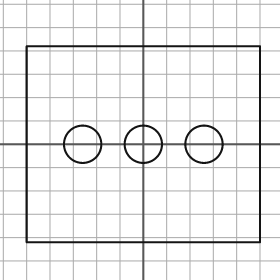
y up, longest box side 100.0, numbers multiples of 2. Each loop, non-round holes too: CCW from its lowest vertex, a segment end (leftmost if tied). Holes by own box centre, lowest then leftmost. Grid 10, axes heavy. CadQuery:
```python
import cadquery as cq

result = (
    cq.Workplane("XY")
    .moveTo(-50.0, -42.0)
    .lineTo(50.0, -42.0)
    .lineTo(50.0, 42.0)
    .lineTo(-50.0, 42.0)
    .close()
    .moveTo(-26.0, 0.0)
    .circle(8.0)
    .moveTo(0.0, 0.0)
    .circle(8.0)
    .moveTo(26.0, 0.0)
    .circle(8.0)
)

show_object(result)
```